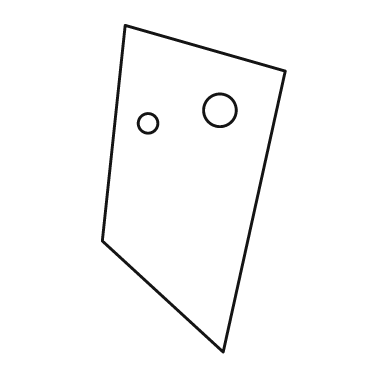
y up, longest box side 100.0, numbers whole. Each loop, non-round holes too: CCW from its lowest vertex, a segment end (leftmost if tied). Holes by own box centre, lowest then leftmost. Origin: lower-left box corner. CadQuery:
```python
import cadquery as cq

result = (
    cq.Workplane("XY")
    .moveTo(37.0, 0.0)
    .lineTo(56.0, 86.0)
    .lineTo(7.0, 100.0)
    .lineTo(0.0, 34.0)
    .close()
    .moveTo(14.0, 70.0)
    .circle(3.0)
    .moveTo(36.0, 74.0)
    .circle(5.0)
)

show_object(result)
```